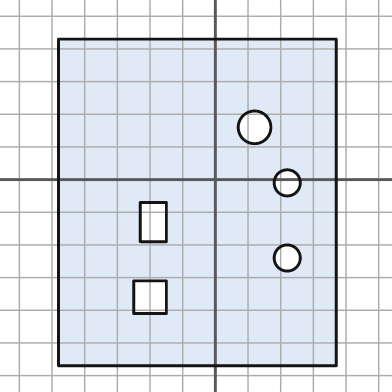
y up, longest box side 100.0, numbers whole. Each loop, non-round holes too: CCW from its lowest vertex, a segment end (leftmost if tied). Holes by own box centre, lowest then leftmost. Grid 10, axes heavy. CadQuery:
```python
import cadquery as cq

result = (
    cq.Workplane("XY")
    .moveTo(-48.0, -57.0)
    .lineTo(37.0, -57.0)
    .lineTo(37.0, 43.0)
    .lineTo(-48.0, 43.0)
    .close()
    .moveTo(-25.0, -41.0)
    .lineTo(-15.0, -41.0)
    .lineTo(-15.0, -31.0)
    .lineTo(-25.0, -31.0)
    .close()
    .moveTo(22.0, -24.0)
    .circle(4.0)
    .moveTo(-23.0, -19.0)
    .lineTo(-15.0, -19.0)
    .lineTo(-15.0, -7.0)
    .lineTo(-23.0, -7.0)
    .close()
    .moveTo(22.0, -1.0)
    .circle(4.0)
    .moveTo(12.0, 16.0)
    .circle(5.0)
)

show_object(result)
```